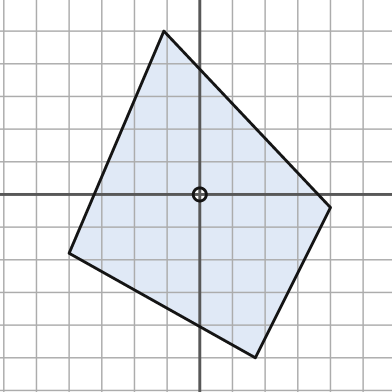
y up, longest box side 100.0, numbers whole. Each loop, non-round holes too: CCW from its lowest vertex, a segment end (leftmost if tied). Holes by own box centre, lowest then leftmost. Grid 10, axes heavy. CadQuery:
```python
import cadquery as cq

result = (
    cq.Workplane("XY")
    .moveTo(17.0, -50.0)
    .lineTo(40.0, -4.0)
    .lineTo(-11.0, 50.0)
    .lineTo(-40.0, -18.0)
    .close()
    .moveTo(0.0, 0.0)
    .circle(2.0)
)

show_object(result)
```